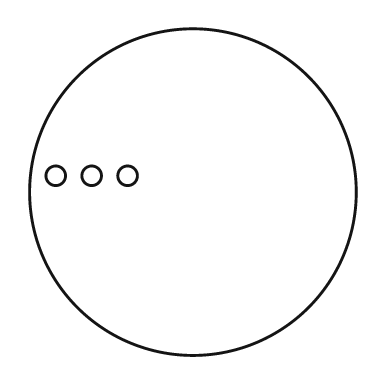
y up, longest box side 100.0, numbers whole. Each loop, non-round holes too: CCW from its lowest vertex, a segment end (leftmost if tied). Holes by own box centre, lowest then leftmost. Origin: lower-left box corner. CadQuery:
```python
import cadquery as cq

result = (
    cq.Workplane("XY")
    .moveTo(50.0, 50.0)
    .circle(50.0)
    .moveTo(8.0, 55.0)
    .circle(3.0)
    .moveTo(19.0, 55.0)
    .circle(3.0)
    .moveTo(30.0, 55.0)
    .circle(3.0)
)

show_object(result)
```